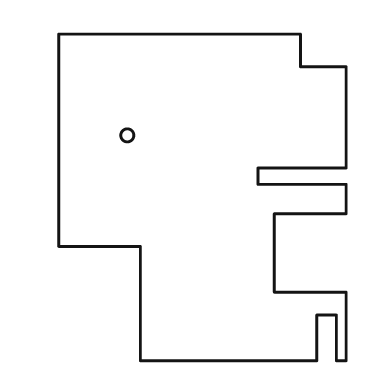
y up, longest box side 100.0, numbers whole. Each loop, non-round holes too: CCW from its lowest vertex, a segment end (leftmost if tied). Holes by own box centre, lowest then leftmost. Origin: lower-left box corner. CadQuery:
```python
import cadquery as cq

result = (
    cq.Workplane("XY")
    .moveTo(25.0, 0.0)
    .lineTo(79.0, 0.0)
    .lineTo(79.0, 14.0)
    .lineTo(85.0, 14.0)
    .lineTo(85.0, 0.0)
    .lineTo(88.0, 0.0)
    .lineTo(88.0, 21.0)
    .lineTo(66.0, 21.0)
    .lineTo(66.0, 45.0)
    .lineTo(88.0, 45.0)
    .lineTo(88.0, 54.0)
    .lineTo(61.0, 54.0)
    .lineTo(61.0, 59.0)
    .lineTo(88.0, 59.0)
    .lineTo(88.0, 90.0)
    .lineTo(74.0, 90.0)
    .lineTo(74.0, 100.0)
    .lineTo(0.0, 100.0)
    .lineTo(0.0, 35.0)
    .lineTo(25.0, 35.0)
    .close()
    .moveTo(21.0, 69.0)
    .circle(2.0)
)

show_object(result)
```